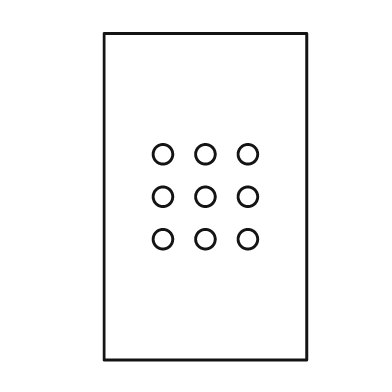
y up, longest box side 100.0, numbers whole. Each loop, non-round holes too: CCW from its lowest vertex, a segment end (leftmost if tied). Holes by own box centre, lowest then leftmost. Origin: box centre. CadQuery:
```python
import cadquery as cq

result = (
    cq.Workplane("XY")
    .moveTo(-31.0, -50.0)
    .lineTo(31.0, -50.0)
    .lineTo(31.0, 50.0)
    .lineTo(-31.0, 50.0)
    .close()
    .moveTo(-13.0, -13.0)
    .circle(3.0)
    .moveTo(0.0, -13.0)
    .circle(3.0)
    .moveTo(13.0, -13.0)
    .circle(3.0)
    .moveTo(-13.0, 0.0)
    .circle(3.0)
    .moveTo(0.0, 0.0)
    .circle(3.0)
    .moveTo(13.0, 0.0)
    .circle(3.0)
    .moveTo(-13.0, 13.0)
    .circle(3.0)
    .moveTo(0.0, 13.0)
    .circle(3.0)
    .moveTo(13.0, 13.0)
    .circle(3.0)
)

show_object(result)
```